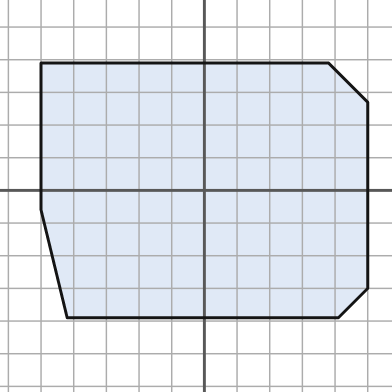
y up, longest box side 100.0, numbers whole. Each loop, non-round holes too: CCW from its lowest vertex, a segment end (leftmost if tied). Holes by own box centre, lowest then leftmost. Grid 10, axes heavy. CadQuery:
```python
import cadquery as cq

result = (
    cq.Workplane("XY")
    .moveTo(-42.0, -39.0)
    .lineTo(41.0, -39.0)
    .lineTo(50.0, -30.0)
    .lineTo(50.0, 27.0)
    .lineTo(38.0, 39.0)
    .lineTo(-50.0, 39.0)
    .lineTo(-50.0, -6.0)
    .close()
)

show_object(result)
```